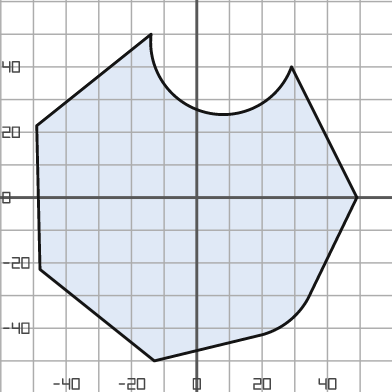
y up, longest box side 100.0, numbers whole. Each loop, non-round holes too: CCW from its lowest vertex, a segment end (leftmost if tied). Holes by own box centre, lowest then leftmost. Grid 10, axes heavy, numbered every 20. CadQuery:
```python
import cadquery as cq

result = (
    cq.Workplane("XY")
    .moveTo(-13.0, -50.0)
    .lineTo(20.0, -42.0)
    .threePointArc((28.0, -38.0), (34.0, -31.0))
    .lineTo(49.0, 0.0)
    .lineTo(29.0, 40.0)
    .threePointArc((3.0, 26.0), (-14.0, 50.0))
    .lineTo(-49.0, 22.0)
    .lineTo(-48.0, -22.0)
    .close()
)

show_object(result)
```